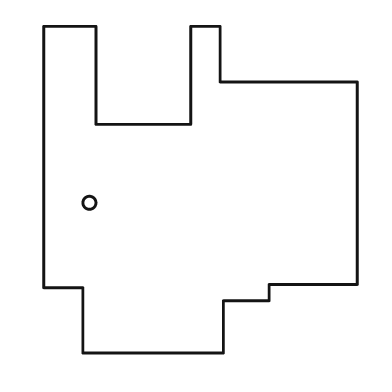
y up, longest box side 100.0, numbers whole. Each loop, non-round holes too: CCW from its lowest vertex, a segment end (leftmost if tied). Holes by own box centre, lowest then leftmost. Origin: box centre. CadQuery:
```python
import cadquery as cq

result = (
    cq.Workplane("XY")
    .moveTo(-36.0, -50.0)
    .lineTo(7.0, -50.0)
    .lineTo(7.0, -34.0)
    .lineTo(21.0, -34.0)
    .lineTo(21.0, -29.0)
    .lineTo(48.0, -29.0)
    .lineTo(48.0, 33.0)
    .lineTo(6.0, 33.0)
    .lineTo(6.0, 50.0)
    .lineTo(-3.0, 50.0)
    .lineTo(-3.0, 20.0)
    .lineTo(-32.0, 20.0)
    .lineTo(-32.0, 50.0)
    .lineTo(-48.0, 50.0)
    .lineTo(-48.0, -30.0)
    .lineTo(-36.0, -30.0)
    .close()
    .moveTo(-34.0, -4.0)
    .circle(2.0)
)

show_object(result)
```